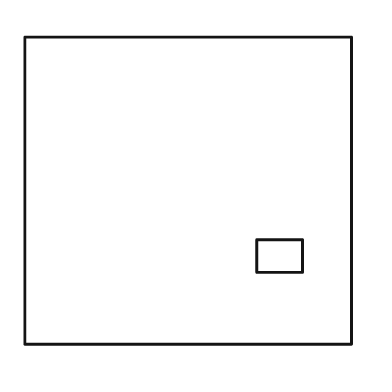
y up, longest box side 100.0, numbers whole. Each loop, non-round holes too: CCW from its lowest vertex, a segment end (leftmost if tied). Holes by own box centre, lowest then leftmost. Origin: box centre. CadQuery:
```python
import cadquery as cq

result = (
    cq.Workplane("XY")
    .moveTo(-50.0, -47.0)
    .lineTo(50.0, -47.0)
    .lineTo(50.0, 47.0)
    .lineTo(-50.0, 47.0)
    .close()
    .moveTo(21.0, -25.0)
    .lineTo(35.0, -25.0)
    .lineTo(35.0, -15.0)
    .lineTo(21.0, -15.0)
    .close()
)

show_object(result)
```